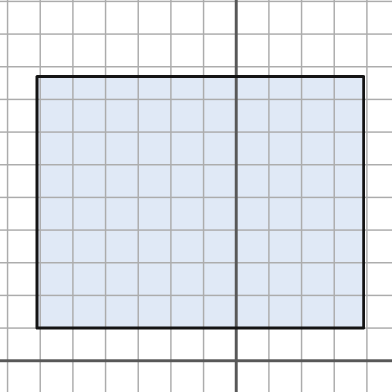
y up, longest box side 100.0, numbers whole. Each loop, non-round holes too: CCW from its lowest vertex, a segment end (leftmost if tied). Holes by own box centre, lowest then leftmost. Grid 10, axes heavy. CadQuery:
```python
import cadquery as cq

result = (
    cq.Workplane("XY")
    .moveTo(-61.0, 10.0)
    .lineTo(39.0, 10.0)
    .lineTo(39.0, 87.0)
    .lineTo(-61.0, 87.0)
    .close()
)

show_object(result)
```